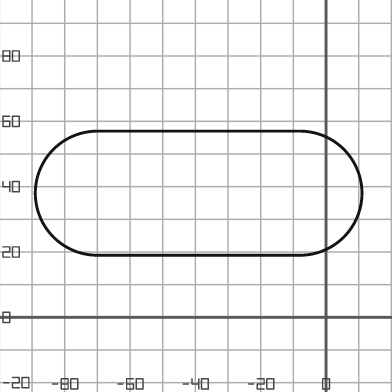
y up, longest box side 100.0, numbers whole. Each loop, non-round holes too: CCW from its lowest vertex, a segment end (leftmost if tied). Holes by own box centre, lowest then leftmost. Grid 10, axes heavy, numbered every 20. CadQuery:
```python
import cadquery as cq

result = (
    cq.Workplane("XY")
    .moveTo(-70.0, 19.0)
    .lineTo(-8.0, 19.0)
    .threePointArc((11.0, 38.0), (-8.0, 57.0))
    .lineTo(-70.0, 57.0)
    .threePointArc((-89.0, 38.0), (-70.0, 19.0))
    .close()
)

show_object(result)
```